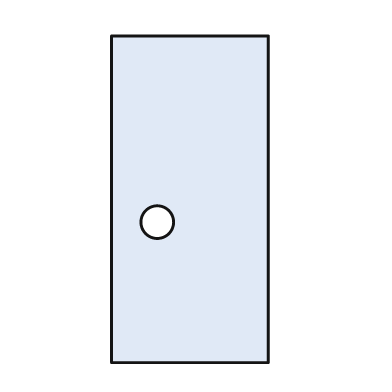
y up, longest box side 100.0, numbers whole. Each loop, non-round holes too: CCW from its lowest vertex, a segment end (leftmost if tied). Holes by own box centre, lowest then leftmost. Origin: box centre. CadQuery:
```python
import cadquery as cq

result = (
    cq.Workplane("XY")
    .moveTo(-24.0, -50.0)
    .lineTo(24.0, -50.0)
    .lineTo(24.0, 50.0)
    .lineTo(-24.0, 50.0)
    .close()
    .moveTo(-10.0, -7.0)
    .circle(5.0)
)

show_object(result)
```